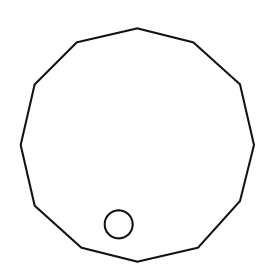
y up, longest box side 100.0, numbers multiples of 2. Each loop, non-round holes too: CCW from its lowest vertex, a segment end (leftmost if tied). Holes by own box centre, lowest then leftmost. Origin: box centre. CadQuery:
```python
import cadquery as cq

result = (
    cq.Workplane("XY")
    .moveTo(0.0, -50.0)
    .lineTo(26.0, -44.0)
    .lineTo(44.0, -24.0)
    .lineTo(50.0, 0.0)
    .lineTo(44.0, 26.0)
    .lineTo(24.0, 44.0)
    .lineTo(0.0, 50.0)
    .lineTo(-26.0, 44.0)
    .lineTo(-44.0, 26.0)
    .lineTo(-50.0, 0.0)
    .lineTo(-44.0, -26.0)
    .lineTo(-24.0, -44.0)
    .close()
    .moveTo(-8.0, -34.0)
    .circle(6.0)
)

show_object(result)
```